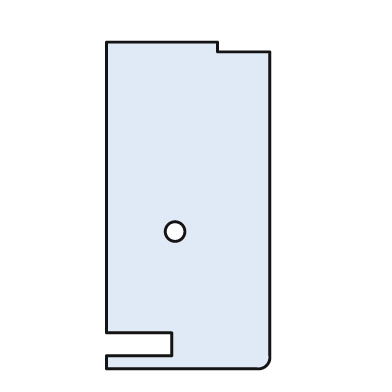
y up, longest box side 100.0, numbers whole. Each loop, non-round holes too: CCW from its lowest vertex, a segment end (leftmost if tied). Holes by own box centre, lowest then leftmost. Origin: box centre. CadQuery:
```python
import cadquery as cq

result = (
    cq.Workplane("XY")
    .moveTo(-25.0, -50.0)
    .lineTo(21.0, -50.0)
    .threePointArc((24.0, -49.0), (25.0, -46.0))
    .lineTo(25.0, 47.0)
    .lineTo(9.0, 47.0)
    .lineTo(9.0, 50.0)
    .lineTo(-25.0, 50.0)
    .lineTo(-25.0, -39.0)
    .lineTo(-5.0, -39.0)
    .lineTo(-5.0, -46.0)
    .lineTo(-25.0, -46.0)
    .close()
    .moveTo(-4.0, -8.0)
    .circle(3.0)
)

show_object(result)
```